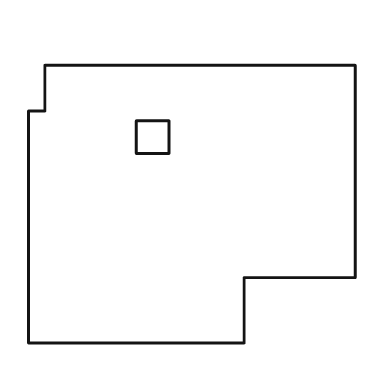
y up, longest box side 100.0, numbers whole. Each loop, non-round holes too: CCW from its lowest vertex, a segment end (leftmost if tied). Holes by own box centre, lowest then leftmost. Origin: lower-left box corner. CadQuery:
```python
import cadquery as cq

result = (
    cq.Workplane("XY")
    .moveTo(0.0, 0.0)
    .lineTo(66.0, 0.0)
    .lineTo(66.0, 20.0)
    .lineTo(100.0, 20.0)
    .lineTo(100.0, 85.0)
    .lineTo(5.0, 85.0)
    .lineTo(5.0, 71.0)
    .lineTo(0.0, 71.0)
    .close()
    .moveTo(33.0, 58.0)
    .lineTo(43.0, 58.0)
    .lineTo(43.0, 68.0)
    .lineTo(33.0, 68.0)
    .close()
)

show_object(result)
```